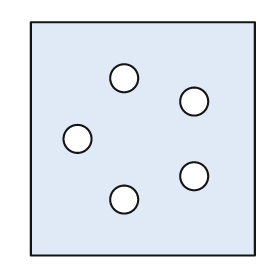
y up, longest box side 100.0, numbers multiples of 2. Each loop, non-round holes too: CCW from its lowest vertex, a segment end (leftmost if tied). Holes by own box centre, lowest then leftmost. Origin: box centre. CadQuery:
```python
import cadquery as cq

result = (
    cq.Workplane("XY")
    .moveTo(-48.0, -50.0)
    .lineTo(48.0, -50.0)
    .lineTo(48.0, 50.0)
    .lineTo(-48.0, 50.0)
    .close()
    .moveTo(-8.0, -26.0)
    .circle(6.0)
    .moveTo(22.0, -16.0)
    .circle(6.0)
    .moveTo(-28.0, 0.0)
    .circle(6.0)
    .moveTo(22.0, 16.0)
    .circle(6.0)
    .moveTo(-8.0, 26.0)
    .circle(6.0)
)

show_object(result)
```